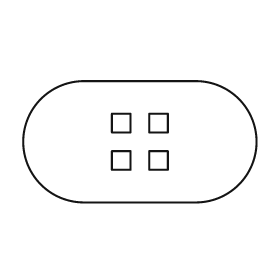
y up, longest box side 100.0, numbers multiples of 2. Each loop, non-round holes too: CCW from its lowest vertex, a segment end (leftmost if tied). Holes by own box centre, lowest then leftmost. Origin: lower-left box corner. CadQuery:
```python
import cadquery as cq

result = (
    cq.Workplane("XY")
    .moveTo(26.0, 0.0)
    .lineTo(74.0, 0.0)
    .threePointArc((100.0, 26.0), (74.0, 52.0))
    .lineTo(26.0, 52.0)
    .threePointArc((0.0, 26.0), (26.0, 0.0))
    .close()
    .moveTo(38.0, 14.0)
    .lineTo(46.0, 14.0)
    .lineTo(46.0, 22.0)
    .lineTo(38.0, 22.0)
    .close()
    .moveTo(54.0, 14.0)
    .lineTo(62.0, 14.0)
    .lineTo(62.0, 22.0)
    .lineTo(54.0, 22.0)
    .close()
    .moveTo(38.0, 30.0)
    .lineTo(46.0, 30.0)
    .lineTo(46.0, 38.0)
    .lineTo(38.0, 38.0)
    .close()
    .moveTo(54.0, 30.0)
    .lineTo(62.0, 30.0)
    .lineTo(62.0, 38.0)
    .lineTo(54.0, 38.0)
    .close()
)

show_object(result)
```